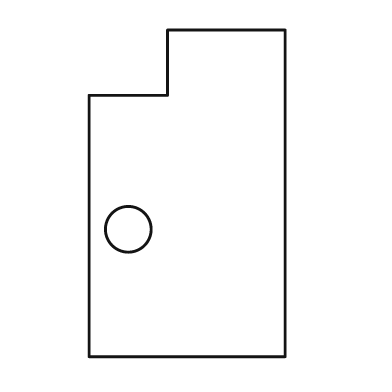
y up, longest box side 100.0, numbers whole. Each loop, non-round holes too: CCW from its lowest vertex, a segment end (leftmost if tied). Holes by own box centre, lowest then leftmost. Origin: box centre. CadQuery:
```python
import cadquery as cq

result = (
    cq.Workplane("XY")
    .moveTo(-30.0, -50.0)
    .lineTo(30.0, -50.0)
    .lineTo(30.0, 50.0)
    .lineTo(-6.0, 50.0)
    .lineTo(-6.0, 30.0)
    .lineTo(-30.0, 30.0)
    .close()
    .moveTo(-18.0, -11.0)
    .circle(7.0)
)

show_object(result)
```